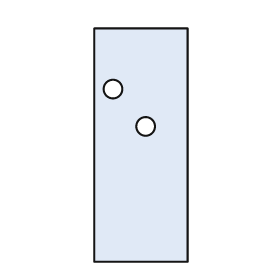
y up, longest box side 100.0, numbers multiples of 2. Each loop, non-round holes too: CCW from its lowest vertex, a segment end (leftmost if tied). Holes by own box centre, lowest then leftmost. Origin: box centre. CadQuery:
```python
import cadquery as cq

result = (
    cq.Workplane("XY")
    .moveTo(-20.0, -50.0)
    .lineTo(20.0, -50.0)
    .lineTo(20.0, 50.0)
    .lineTo(-20.0, 50.0)
    .close()
    .moveTo(2.0, 8.0)
    .circle(4.0)
    .moveTo(-12.0, 24.0)
    .circle(4.0)
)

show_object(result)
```